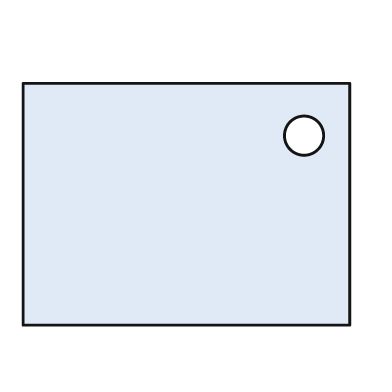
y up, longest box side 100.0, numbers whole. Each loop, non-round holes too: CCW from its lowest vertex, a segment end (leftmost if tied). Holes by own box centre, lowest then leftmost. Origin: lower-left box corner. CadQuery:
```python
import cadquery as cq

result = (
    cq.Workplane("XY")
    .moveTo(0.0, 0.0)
    .lineTo(100.0, 0.0)
    .lineTo(100.0, 74.0)
    .lineTo(0.0, 74.0)
    .close()
    .moveTo(86.0, 58.0)
    .circle(6.0)
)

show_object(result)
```